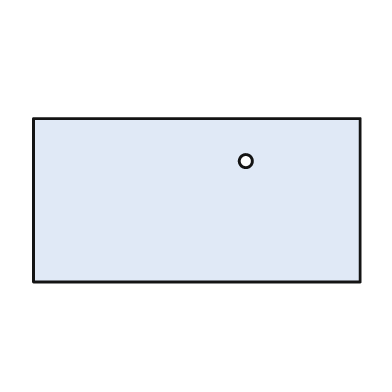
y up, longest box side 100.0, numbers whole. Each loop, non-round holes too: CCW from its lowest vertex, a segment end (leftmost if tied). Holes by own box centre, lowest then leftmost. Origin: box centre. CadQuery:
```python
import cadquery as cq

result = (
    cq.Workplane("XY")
    .moveTo(-50.0, -25.0)
    .lineTo(50.0, -25.0)
    .lineTo(50.0, 25.0)
    .lineTo(-50.0, 25.0)
    .close()
    .moveTo(15.0, 12.0)
    .circle(2.0)
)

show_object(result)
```